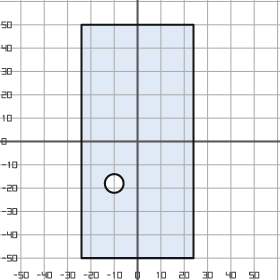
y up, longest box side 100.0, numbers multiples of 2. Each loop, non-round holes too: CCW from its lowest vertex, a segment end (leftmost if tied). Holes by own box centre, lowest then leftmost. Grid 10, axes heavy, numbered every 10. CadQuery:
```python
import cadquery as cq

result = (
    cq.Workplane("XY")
    .moveTo(-24.0, -50.0)
    .lineTo(24.0, -50.0)
    .lineTo(24.0, 50.0)
    .lineTo(-24.0, 50.0)
    .close()
    .moveTo(-10.0, -18.0)
    .circle(4.0)
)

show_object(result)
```